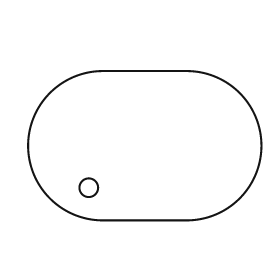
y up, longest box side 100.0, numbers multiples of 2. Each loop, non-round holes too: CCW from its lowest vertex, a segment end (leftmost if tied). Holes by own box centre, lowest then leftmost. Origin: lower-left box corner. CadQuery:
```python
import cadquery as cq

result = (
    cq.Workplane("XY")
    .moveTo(32.0, 0.0)
    .lineTo(68.0, 0.0)
    .threePointArc((100.0, 32.0), (68.0, 64.0))
    .lineTo(32.0, 64.0)
    .threePointArc((0.0, 32.0), (32.0, 0.0))
    .close()
    .moveTo(26.0, 14.0)
    .circle(4.0)
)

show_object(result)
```